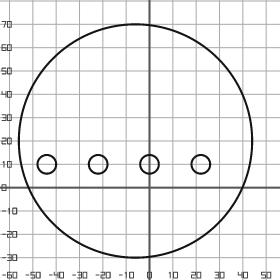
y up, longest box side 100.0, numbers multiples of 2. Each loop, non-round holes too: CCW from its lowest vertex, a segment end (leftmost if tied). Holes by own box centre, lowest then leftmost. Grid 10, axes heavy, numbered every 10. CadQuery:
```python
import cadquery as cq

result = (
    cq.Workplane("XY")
    .moveTo(-6.0, 20.0)
    .circle(50.0)
    .moveTo(-44.0, 10.0)
    .circle(4.0)
    .moveTo(-22.0, 10.0)
    .circle(4.0)
    .moveTo(0.0, 10.0)
    .circle(4.0)
    .moveTo(22.0, 10.0)
    .circle(4.0)
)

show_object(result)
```